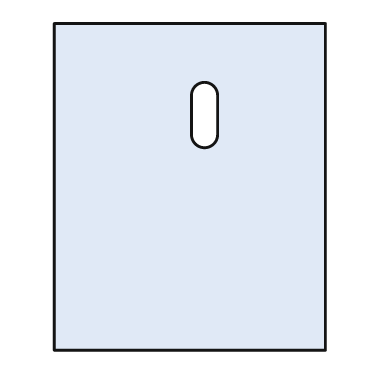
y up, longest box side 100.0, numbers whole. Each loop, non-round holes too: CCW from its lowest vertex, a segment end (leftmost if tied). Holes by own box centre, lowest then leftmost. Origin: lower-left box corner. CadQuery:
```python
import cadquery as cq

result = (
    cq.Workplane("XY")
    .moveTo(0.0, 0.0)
    .lineTo(83.0, 0.0)
    .lineTo(83.0, 100.0)
    .lineTo(0.0, 100.0)
    .close()
    .moveTo(42.0, 66.0)
    .threePointArc((46.0, 62.0), (50.0, 66.0))
    .lineTo(50.0, 78.0)
    .threePointArc((46.0, 82.0), (42.0, 78.0))
    .close()
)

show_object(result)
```